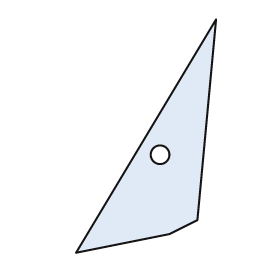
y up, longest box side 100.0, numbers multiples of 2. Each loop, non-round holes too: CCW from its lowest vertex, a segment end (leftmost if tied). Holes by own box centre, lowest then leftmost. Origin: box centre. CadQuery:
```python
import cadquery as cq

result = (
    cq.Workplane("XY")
    .moveTo(-30.0, -50.0)
    .lineTo(10.0, -42.0)
    .lineTo(22.0, -36.0)
    .lineTo(30.0, 50.0)
    .close()
    .moveTo(6.0, -8.0)
    .circle(4.0)
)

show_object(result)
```